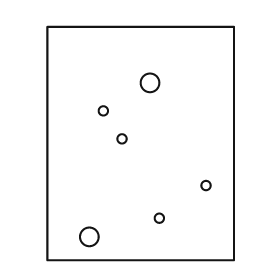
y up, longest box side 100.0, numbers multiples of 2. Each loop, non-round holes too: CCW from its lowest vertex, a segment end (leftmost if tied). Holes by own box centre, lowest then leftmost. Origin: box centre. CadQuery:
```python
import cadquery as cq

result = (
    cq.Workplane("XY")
    .moveTo(-40.0, -50.0)
    .lineTo(40.0, -50.0)
    .lineTo(40.0, 50.0)
    .lineTo(-40.0, 50.0)
    .close()
    .moveTo(-22.0, -40.0)
    .circle(4.0)
    .moveTo(8.0, -32.0)
    .circle(2.0)
    .moveTo(28.0, -18.0)
    .circle(2.0)
    .moveTo(-8.0, 2.0)
    .circle(2.0)
    .moveTo(-16.0, 14.0)
    .circle(2.0)
    .moveTo(4.0, 26.0)
    .circle(4.0)
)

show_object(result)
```